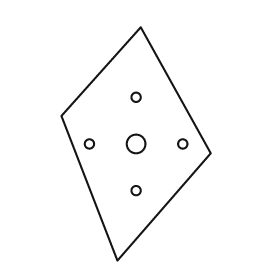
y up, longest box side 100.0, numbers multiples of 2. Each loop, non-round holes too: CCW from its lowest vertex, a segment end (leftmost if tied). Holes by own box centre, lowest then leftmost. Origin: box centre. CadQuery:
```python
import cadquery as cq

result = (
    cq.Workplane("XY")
    .moveTo(-8.0, -50.0)
    .lineTo(32.0, -4.0)
    .lineTo(2.0, 50.0)
    .lineTo(-32.0, 12.0)
    .close()
    .moveTo(0.0, -20.0)
    .circle(2.0)
    .moveTo(-20.0, 0.0)
    .circle(2.0)
    .moveTo(0.0, 0.0)
    .circle(4.0)
    .moveTo(20.0, 0.0)
    .circle(2.0)
    .moveTo(0.0, 20.0)
    .circle(2.0)
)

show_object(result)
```